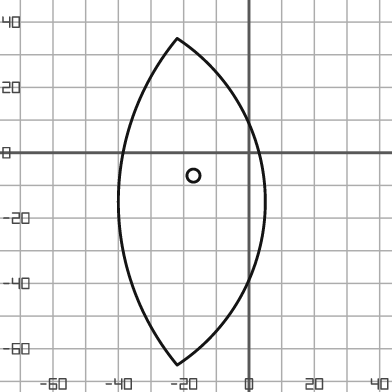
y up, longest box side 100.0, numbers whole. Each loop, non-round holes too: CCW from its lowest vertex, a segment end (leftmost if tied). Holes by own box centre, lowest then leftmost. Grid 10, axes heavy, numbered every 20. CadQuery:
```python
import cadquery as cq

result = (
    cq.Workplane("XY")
    .moveTo(-22.0, -65.0)
    .threePointArc((5.0, -15.0), (-22.0, 35.0))
    .threePointArc((-40.0, -15.0), (-22.0, -65.0))
    .close()
    .moveTo(-17.0, -7.0)
    .circle(2.0)
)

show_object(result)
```